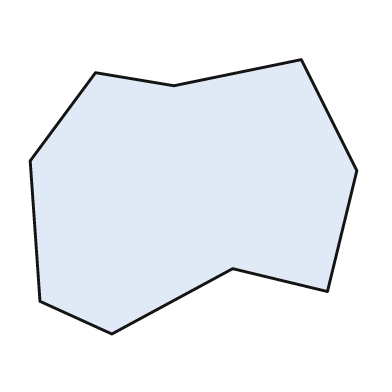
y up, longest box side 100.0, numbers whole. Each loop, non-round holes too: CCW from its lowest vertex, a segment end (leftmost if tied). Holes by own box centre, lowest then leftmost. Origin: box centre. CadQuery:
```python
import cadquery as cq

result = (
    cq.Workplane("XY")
    .moveTo(-25.0, -42.0)
    .lineTo(12.0, -22.0)
    .lineTo(41.0, -29.0)
    .lineTo(50.0, 8.0)
    .lineTo(33.0, 42.0)
    .lineTo(-6.0, 34.0)
    .lineTo(-30.0, 38.0)
    .lineTo(-50.0, 11.0)
    .lineTo(-47.0, -32.0)
    .close()
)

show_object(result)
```